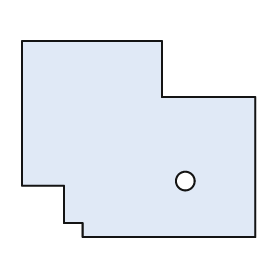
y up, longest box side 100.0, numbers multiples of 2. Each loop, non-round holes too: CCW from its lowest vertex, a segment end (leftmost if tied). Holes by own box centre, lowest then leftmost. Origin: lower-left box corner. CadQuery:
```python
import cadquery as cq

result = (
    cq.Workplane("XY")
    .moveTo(26.0, 0.0)
    .lineTo(100.0, 0.0)
    .lineTo(100.0, 60.0)
    .lineTo(60.0, 60.0)
    .lineTo(60.0, 84.0)
    .lineTo(0.0, 84.0)
    .lineTo(0.0, 22.0)
    .lineTo(18.0, 22.0)
    .lineTo(18.0, 6.0)
    .lineTo(26.0, 6.0)
    .close()
    .moveTo(70.0, 24.0)
    .circle(4.0)
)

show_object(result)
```